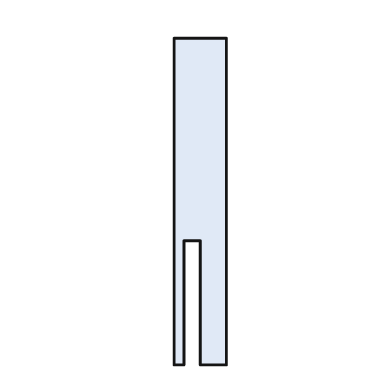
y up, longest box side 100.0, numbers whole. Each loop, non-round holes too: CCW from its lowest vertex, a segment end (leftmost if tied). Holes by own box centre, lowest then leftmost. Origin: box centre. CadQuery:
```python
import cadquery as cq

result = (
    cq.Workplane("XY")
    .moveTo(-8.0, -50.0)
    .lineTo(-5.0, -50.0)
    .lineTo(-5.0, -12.0)
    .lineTo(0.0, -12.0)
    .lineTo(0.0, -50.0)
    .lineTo(8.0, -50.0)
    .lineTo(8.0, 50.0)
    .lineTo(-8.0, 50.0)
    .close()
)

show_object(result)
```